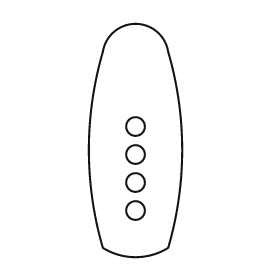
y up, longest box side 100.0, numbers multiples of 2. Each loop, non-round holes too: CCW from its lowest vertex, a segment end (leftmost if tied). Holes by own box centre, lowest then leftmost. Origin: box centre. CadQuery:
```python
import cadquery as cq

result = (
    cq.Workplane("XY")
    .moveTo(-14.0, -46.0)
    .threePointArc((0.0, -50.0), (14.0, -46.0))
    .threePointArc((20.0, -4.0), (14.0, 38.0))
    .threePointArc((0.0, 50.0), (-14.0, 38.0))
    .threePointArc((-20.0, -4.0), (-14.0, -46.0))
    .close()
    .moveTo(0.0, -30.0)
    .circle(4.0)
    .moveTo(0.0, -18.0)
    .circle(4.0)
    .moveTo(0.0, -6.0)
    .circle(4.0)
    .moveTo(0.0, 6.0)
    .circle(4.0)
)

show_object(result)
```